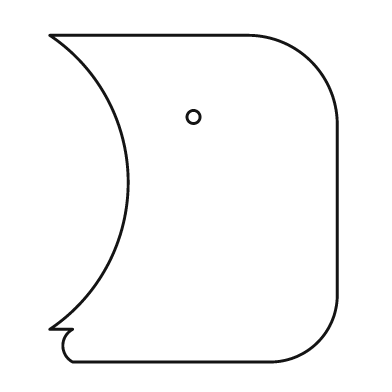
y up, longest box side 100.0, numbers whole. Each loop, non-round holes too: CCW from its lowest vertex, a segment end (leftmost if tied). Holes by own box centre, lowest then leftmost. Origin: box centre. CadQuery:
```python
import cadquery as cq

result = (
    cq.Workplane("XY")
    .moveTo(-37.0, -50.0)
    .lineTo(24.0, -50.0)
    .threePointArc((38.0, -44.0), (44.0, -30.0))
    .lineTo(44.0, 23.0)
    .threePointArc((36.0, 42.0), (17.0, 50.0))
    .lineTo(-44.0, 50.0)
    .threePointArc((-20.0, 5.0), (-44.0, -40.0))
    .lineTo(-37.0, -40.0)
    .threePointArc((-40.0, -45.0), (-37.0, -50.0))
    .close()
    .moveTo(0.0, 25.0)
    .circle(2.0)
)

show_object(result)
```